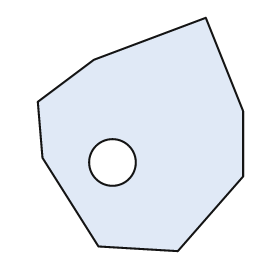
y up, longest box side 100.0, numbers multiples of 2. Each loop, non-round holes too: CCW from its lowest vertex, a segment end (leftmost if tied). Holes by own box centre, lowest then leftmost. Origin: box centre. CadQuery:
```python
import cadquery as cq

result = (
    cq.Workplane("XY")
    .moveTo(16.0, -50.0)
    .lineTo(44.0, -18.0)
    .lineTo(44.0, 10.0)
    .lineTo(28.0, 50.0)
    .lineTo(-20.0, 32.0)
    .lineTo(-44.0, 14.0)
    .lineTo(-42.0, -10.0)
    .lineTo(-18.0, -48.0)
    .close()
    .moveTo(-12.0, -12.0)
    .circle(10.0)
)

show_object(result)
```